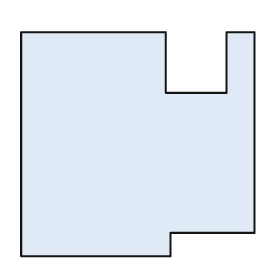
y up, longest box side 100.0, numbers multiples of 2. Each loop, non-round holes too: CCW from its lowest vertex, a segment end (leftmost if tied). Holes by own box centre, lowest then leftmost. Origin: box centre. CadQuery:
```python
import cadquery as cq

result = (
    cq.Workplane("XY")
    .moveTo(-50.0, -48.0)
    .lineTo(14.0, -48.0)
    .lineTo(14.0, -38.0)
    .lineTo(50.0, -38.0)
    .lineTo(50.0, 48.0)
    .lineTo(38.0, 48.0)
    .lineTo(38.0, 22.0)
    .lineTo(12.0, 22.0)
    .lineTo(12.0, 48.0)
    .lineTo(-50.0, 48.0)
    .close()
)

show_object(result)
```